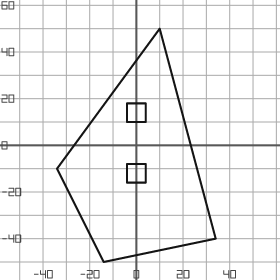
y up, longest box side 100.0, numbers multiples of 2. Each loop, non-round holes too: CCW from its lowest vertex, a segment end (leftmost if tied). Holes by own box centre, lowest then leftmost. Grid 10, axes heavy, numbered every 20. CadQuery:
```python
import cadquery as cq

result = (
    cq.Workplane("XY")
    .moveTo(-14.0, -50.0)
    .lineTo(34.0, -40.0)
    .lineTo(10.0, 50.0)
    .lineTo(-34.0, -10.0)
    .close()
    .moveTo(-4.0, -16.0)
    .lineTo(4.0, -16.0)
    .lineTo(4.0, -8.0)
    .lineTo(-4.0, -8.0)
    .close()
    .moveTo(-4.0, 10.0)
    .lineTo(4.0, 10.0)
    .lineTo(4.0, 18.0)
    .lineTo(-4.0, 18.0)
    .close()
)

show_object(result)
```